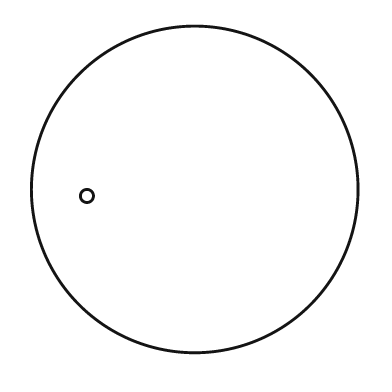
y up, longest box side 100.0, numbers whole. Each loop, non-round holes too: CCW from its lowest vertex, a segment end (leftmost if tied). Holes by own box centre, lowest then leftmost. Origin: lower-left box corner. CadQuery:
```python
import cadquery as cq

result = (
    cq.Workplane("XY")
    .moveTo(50.0, 50.0)
    .circle(50.0)
    .moveTo(17.0, 48.0)
    .circle(2.0)
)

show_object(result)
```